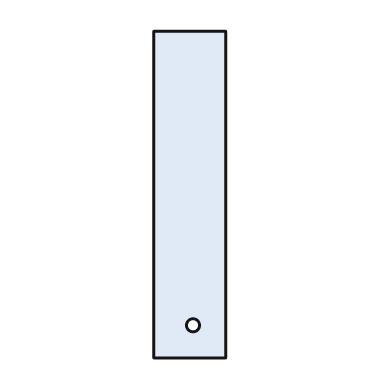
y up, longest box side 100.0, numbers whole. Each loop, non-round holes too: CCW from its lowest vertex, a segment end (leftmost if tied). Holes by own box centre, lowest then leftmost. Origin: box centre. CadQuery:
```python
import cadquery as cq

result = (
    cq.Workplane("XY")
    .moveTo(-11.0, -50.0)
    .lineTo(11.0, -50.0)
    .lineTo(11.0, 50.0)
    .lineTo(-11.0, 50.0)
    .close()
    .moveTo(1.0, -40.0)
    .circle(2.0)
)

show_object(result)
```